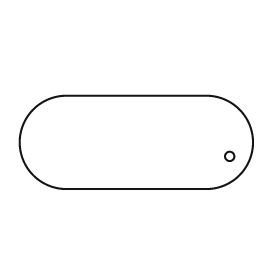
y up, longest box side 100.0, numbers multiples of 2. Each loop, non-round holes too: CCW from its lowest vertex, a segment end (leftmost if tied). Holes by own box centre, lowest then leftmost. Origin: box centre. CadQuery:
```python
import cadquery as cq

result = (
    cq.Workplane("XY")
    .moveTo(-30.0, -20.0)
    .lineTo(30.0, -20.0)
    .threePointArc((50.0, 0.0), (30.0, 20.0))
    .lineTo(-30.0, 20.0)
    .threePointArc((-50.0, 0.0), (-30.0, -20.0))
    .close()
    .moveTo(40.0, -6.0)
    .circle(2.0)
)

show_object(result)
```